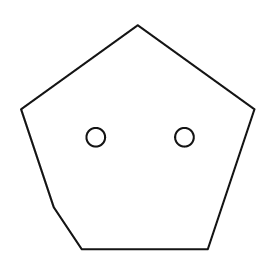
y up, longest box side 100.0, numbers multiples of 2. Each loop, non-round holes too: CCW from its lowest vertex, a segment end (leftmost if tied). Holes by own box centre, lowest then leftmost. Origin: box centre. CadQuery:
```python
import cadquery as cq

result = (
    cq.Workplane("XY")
    .moveTo(-24.0, -48.0)
    .lineTo(30.0, -48.0)
    .lineTo(50.0, 12.0)
    .lineTo(0.0, 48.0)
    .lineTo(-50.0, 12.0)
    .lineTo(-36.0, -30.0)
    .close()
    .moveTo(-18.0, 0.0)
    .circle(4.0)
    .moveTo(20.0, 0.0)
    .circle(4.0)
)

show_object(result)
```